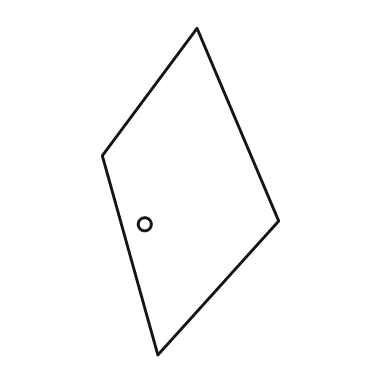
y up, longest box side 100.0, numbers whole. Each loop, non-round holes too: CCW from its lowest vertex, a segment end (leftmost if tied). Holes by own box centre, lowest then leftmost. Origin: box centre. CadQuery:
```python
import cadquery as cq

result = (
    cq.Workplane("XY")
    .moveTo(-10.0, -50.0)
    .lineTo(27.0, -9.0)
    .lineTo(2.0, 50.0)
    .lineTo(-27.0, 11.0)
    .close()
    .moveTo(-14.0, -10.0)
    .circle(2.0)
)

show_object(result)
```